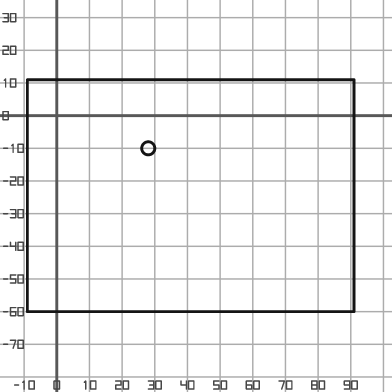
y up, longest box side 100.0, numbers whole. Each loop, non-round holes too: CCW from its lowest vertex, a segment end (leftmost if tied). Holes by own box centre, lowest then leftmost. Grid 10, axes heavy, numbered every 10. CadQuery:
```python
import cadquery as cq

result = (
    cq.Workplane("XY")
    .moveTo(-9.0, -60.0)
    .lineTo(91.0, -60.0)
    .lineTo(91.0, 11.0)
    .lineTo(-9.0, 11.0)
    .close()
    .moveTo(28.0, -10.0)
    .circle(2.0)
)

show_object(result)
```